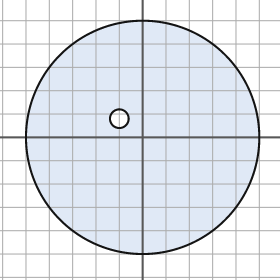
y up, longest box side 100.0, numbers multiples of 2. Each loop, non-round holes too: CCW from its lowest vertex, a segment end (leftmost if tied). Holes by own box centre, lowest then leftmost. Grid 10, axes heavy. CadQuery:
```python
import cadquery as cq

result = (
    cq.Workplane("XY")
    .moveTo(0.0, 0.0)
    .circle(50.0)
    .moveTo(-10.0, 8.0)
    .circle(4.0)
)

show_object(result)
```